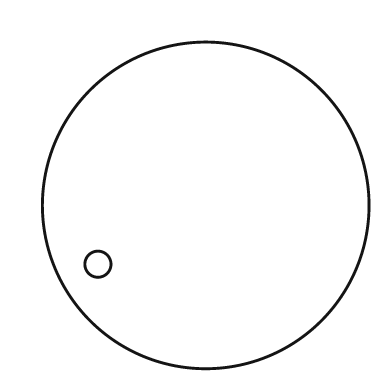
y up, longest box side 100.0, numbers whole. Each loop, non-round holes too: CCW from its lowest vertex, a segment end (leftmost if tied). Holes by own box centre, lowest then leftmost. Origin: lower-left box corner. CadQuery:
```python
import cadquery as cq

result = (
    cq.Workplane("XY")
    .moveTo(50.0, 50.0)
    .circle(50.0)
    .moveTo(17.0, 32.0)
    .circle(4.0)
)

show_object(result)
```